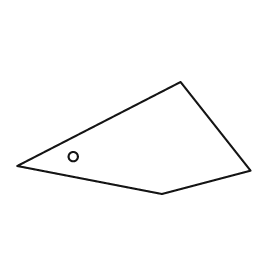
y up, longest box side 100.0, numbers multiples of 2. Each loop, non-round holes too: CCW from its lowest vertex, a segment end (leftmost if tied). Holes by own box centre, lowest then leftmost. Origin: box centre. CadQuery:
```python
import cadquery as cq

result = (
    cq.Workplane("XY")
    .moveTo(12.0, -24.0)
    .lineTo(50.0, -14.0)
    .lineTo(20.0, 24.0)
    .lineTo(-50.0, -12.0)
    .close()
    .moveTo(-26.0, -8.0)
    .circle(2.0)
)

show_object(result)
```